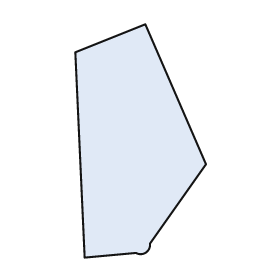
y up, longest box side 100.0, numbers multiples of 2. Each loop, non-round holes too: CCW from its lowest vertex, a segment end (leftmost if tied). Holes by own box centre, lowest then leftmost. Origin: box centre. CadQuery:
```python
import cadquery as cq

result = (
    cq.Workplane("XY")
    .moveTo(-24.0, -50.0)
    .lineTo(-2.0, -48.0)
    .threePointArc((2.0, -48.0), (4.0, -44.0))
    .lineTo(28.0, -10.0)
    .lineTo(2.0, 50.0)
    .lineTo(-28.0, 38.0)
    .close()
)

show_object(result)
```